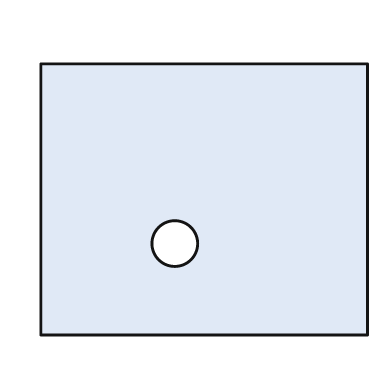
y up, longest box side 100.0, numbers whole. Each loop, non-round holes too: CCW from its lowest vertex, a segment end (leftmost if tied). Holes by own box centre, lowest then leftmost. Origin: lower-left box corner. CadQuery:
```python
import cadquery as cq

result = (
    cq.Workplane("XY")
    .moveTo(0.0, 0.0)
    .lineTo(100.0, 0.0)
    .lineTo(100.0, 83.0)
    .lineTo(0.0, 83.0)
    .close()
    .moveTo(41.0, 28.0)
    .circle(7.0)
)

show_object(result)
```